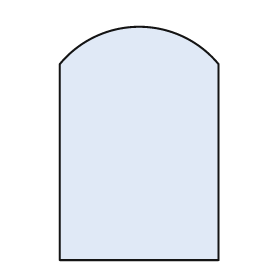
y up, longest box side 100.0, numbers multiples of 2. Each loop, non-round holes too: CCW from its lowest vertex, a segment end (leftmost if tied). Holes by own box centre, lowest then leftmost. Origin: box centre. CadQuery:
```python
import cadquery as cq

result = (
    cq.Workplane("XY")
    .moveTo(-34.0, -50.0)
    .lineTo(34.0, -50.0)
    .lineTo(34.0, 34.0)
    .threePointArc((0.0, 50.0), (-34.0, 34.0))
    .close()
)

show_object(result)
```